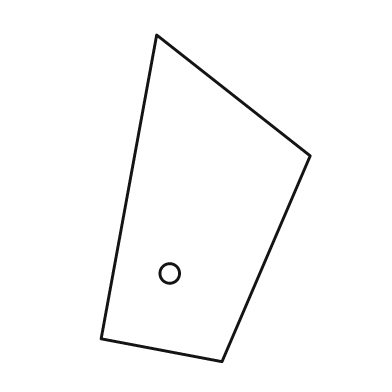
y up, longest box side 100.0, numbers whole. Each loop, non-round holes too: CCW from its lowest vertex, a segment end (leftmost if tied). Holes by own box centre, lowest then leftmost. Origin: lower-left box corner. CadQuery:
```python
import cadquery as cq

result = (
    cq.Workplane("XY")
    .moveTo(37.0, 0.0)
    .lineTo(64.0, 63.0)
    .lineTo(17.0, 100.0)
    .lineTo(0.0, 7.0)
    .close()
    .moveTo(21.0, 27.0)
    .circle(3.0)
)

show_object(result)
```